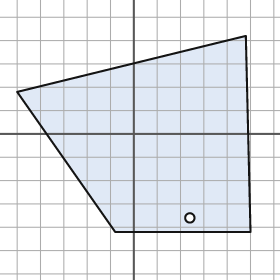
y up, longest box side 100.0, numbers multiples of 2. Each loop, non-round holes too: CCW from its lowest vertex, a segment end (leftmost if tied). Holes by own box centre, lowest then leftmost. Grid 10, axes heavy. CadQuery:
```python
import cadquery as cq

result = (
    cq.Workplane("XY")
    .moveTo(-8.0, -42.0)
    .lineTo(50.0, -42.0)
    .lineTo(48.0, 42.0)
    .lineTo(-50.0, 18.0)
    .close()
    .moveTo(24.0, -36.0)
    .circle(2.0)
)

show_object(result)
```